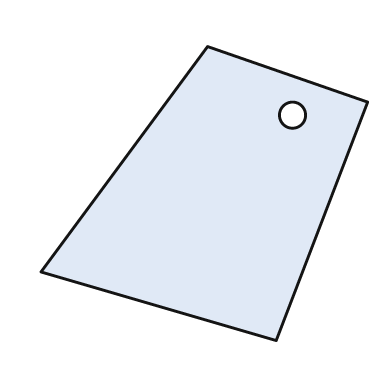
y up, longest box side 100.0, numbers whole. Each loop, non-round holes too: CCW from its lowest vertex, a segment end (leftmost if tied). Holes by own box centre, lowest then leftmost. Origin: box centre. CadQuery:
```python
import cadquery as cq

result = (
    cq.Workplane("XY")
    .moveTo(22.0, -45.0)
    .lineTo(50.0, 28.0)
    .lineTo(1.0, 45.0)
    .lineTo(-50.0, -24.0)
    .close()
    .moveTo(27.0, 24.0)
    .circle(4.0)
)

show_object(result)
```